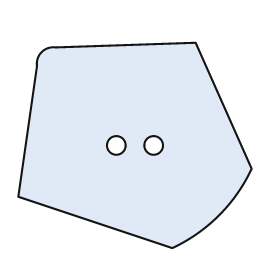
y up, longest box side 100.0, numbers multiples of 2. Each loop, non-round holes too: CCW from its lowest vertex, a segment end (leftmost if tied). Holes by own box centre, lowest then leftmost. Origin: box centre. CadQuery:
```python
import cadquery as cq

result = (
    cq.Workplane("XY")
    .moveTo(16.0, -44.0)
    .threePointArc((36.0, -30.0), (50.0, -10.0))
    .lineTo(26.0, 44.0)
    .lineTo(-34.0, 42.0)
    .threePointArc((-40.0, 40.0), (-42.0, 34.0))
    .lineTo(-50.0, -22.0)
    .close()
    .moveTo(-8.0, 0.0)
    .circle(4.0)
    .moveTo(8.0, 0.0)
    .circle(4.0)
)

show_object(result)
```